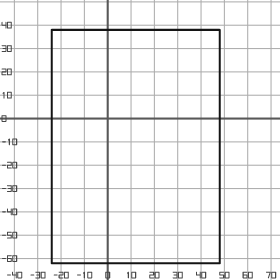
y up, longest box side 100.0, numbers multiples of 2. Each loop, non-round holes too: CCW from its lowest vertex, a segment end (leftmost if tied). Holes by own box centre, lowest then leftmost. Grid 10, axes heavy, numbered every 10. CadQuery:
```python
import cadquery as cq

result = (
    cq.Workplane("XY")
    .moveTo(-24.0, -62.0)
    .lineTo(48.0, -62.0)
    .lineTo(48.0, 38.0)
    .lineTo(-24.0, 38.0)
    .close()
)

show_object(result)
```